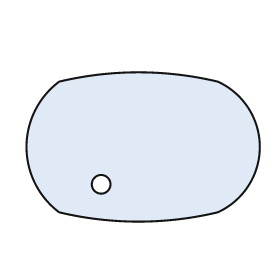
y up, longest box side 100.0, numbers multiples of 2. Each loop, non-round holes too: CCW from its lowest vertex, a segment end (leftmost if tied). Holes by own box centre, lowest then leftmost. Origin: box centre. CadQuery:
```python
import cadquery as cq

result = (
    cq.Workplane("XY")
    .moveTo(-36.0, -28.0)
    .threePointArc((-2.0, -32.0), (32.0, -28.0))
    .threePointArc((50.0, 0.0), (32.0, 28.0))
    .threePointArc((-2.0, 32.0), (-36.0, 28.0))
    .threePointArc((-50.0, 0.0), (-36.0, -28.0))
    .close()
    .moveTo(-18.0, -16.0)
    .circle(4.0)
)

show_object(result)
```